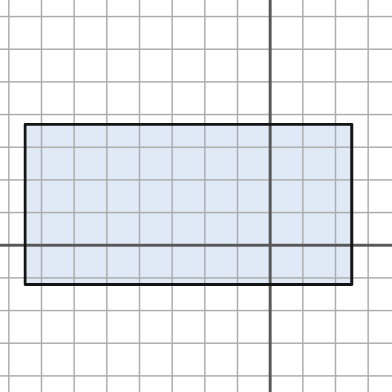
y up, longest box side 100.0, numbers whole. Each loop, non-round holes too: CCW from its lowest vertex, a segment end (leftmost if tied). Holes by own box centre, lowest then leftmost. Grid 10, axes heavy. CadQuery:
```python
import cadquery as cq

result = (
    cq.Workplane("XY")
    .moveTo(-75.0, -12.0)
    .lineTo(25.0, -12.0)
    .lineTo(25.0, 37.0)
    .lineTo(-75.0, 37.0)
    .close()
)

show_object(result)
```